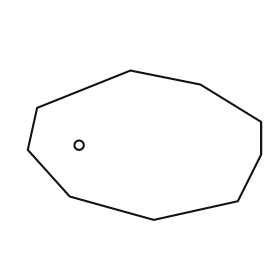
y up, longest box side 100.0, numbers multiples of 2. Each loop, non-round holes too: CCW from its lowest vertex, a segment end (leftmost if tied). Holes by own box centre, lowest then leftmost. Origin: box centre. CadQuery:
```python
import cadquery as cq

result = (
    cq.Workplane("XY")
    .moveTo(4.0, -32.0)
    .lineTo(40.0, -24.0)
    .lineTo(50.0, -4.0)
    .lineTo(50.0, 10.0)
    .lineTo(24.0, 26.0)
    .lineTo(-6.0, 32.0)
    .lineTo(-46.0, 16.0)
    .lineTo(-50.0, -2.0)
    .lineTo(-32.0, -22.0)
    .close()
    .moveTo(-28.0, 0.0)
    .circle(2.0)
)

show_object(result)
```